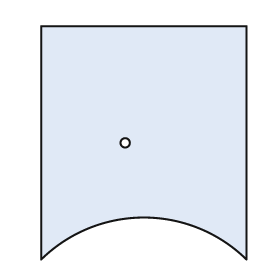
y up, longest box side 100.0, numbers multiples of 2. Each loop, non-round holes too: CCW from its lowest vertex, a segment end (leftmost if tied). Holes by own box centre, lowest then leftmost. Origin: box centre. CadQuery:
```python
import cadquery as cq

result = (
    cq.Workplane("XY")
    .moveTo(-44.0, -50.0)
    .threePointArc((0.0, -32.0), (44.0, -50.0))
    .lineTo(44.0, 50.0)
    .lineTo(-44.0, 50.0)
    .close()
    .moveTo(-8.0, 0.0)
    .circle(2.0)
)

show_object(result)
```